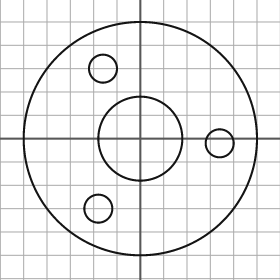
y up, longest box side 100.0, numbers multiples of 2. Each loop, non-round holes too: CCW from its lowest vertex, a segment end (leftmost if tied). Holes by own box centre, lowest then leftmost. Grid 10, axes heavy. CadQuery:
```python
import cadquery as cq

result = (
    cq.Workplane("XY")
    .moveTo(0.0, 0.0)
    .circle(50.0)
    .moveTo(-18.0, -30.0)
    .circle(6.0)
    .moveTo(34.0, -2.0)
    .circle(6.0)
    .moveTo(0.0, 0.0)
    .circle(18.0)
    .moveTo(-16.0, 30.0)
    .circle(6.0)
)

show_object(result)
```